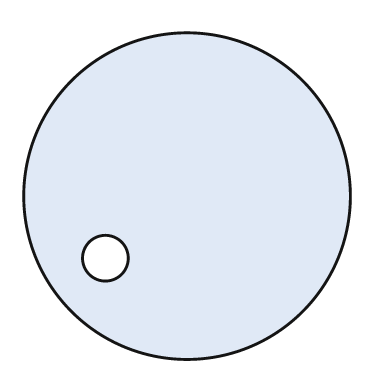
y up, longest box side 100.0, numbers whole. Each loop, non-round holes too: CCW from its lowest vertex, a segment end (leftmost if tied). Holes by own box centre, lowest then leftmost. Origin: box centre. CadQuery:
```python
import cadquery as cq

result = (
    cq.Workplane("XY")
    .moveTo(0.0, 0.0)
    .circle(50.0)
    .moveTo(-25.0, -19.0)
    .circle(7.0)
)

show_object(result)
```